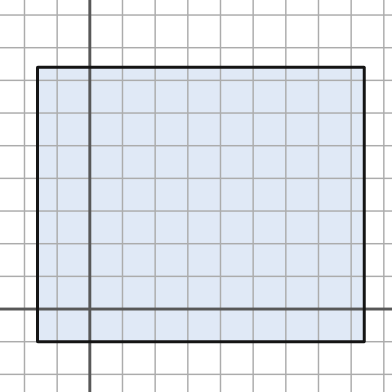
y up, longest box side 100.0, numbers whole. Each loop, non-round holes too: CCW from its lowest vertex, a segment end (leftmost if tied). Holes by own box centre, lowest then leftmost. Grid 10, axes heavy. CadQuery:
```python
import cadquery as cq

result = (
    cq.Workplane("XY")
    .moveTo(-16.0, -10.0)
    .lineTo(84.0, -10.0)
    .lineTo(84.0, 74.0)
    .lineTo(-16.0, 74.0)
    .close()
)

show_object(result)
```